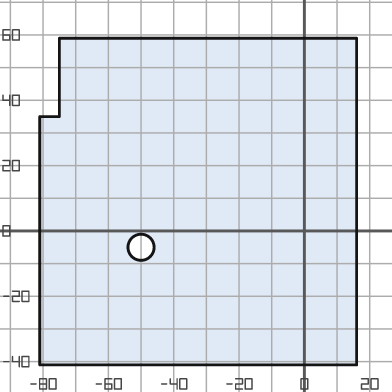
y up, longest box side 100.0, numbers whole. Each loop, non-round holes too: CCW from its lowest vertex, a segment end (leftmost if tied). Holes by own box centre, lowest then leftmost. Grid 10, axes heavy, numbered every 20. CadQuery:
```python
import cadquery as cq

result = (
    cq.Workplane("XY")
    .moveTo(-81.0, -41.0)
    .lineTo(16.0, -41.0)
    .lineTo(16.0, 59.0)
    .lineTo(-75.0, 59.0)
    .lineTo(-75.0, 35.0)
    .lineTo(-81.0, 35.0)
    .close()
    .moveTo(-50.0, -5.0)
    .circle(4.0)
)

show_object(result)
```